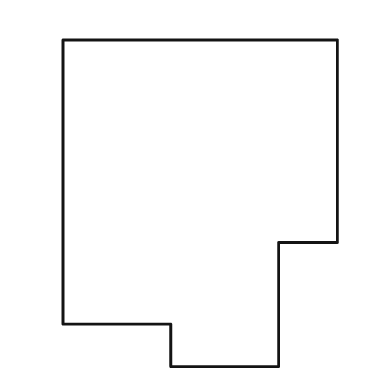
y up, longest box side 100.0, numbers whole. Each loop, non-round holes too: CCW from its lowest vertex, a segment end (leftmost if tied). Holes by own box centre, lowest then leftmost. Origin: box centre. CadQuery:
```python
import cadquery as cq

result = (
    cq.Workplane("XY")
    .moveTo(-9.0, -50.0)
    .lineTo(24.0, -50.0)
    .lineTo(24.0, -12.0)
    .lineTo(42.0, -12.0)
    .lineTo(42.0, 50.0)
    .lineTo(-42.0, 50.0)
    .lineTo(-42.0, -37.0)
    .lineTo(-9.0, -37.0)
    .close()
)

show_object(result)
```